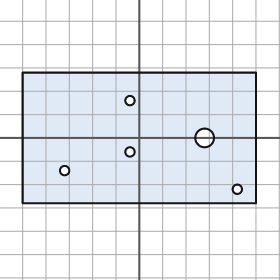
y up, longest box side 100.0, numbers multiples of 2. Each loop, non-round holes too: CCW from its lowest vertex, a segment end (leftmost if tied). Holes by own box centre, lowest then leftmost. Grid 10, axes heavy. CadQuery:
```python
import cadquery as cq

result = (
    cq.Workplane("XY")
    .moveTo(-50.0, -28.0)
    .lineTo(50.0, -28.0)
    .lineTo(50.0, 28.0)
    .lineTo(-50.0, 28.0)
    .close()
    .moveTo(42.0, -22.0)
    .circle(2.0)
    .moveTo(-32.0, -14.0)
    .circle(2.0)
    .moveTo(-4.0, -6.0)
    .circle(2.0)
    .moveTo(28.0, 0.0)
    .circle(4.0)
    .moveTo(-4.0, 16.0)
    .circle(2.0)
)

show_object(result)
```